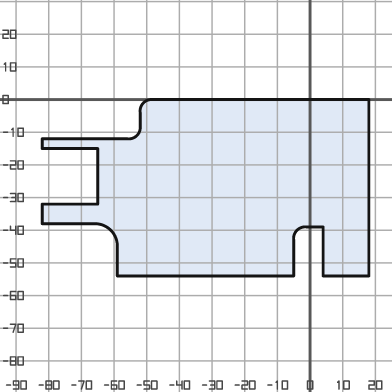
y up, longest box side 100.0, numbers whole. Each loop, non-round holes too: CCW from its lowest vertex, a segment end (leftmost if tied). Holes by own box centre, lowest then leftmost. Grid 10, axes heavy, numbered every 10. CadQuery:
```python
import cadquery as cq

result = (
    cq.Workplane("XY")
    .moveTo(-59.0, -54.0)
    .lineTo(-5.0, -54.0)
    .lineTo(-5.0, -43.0)
    .threePointArc((-4.0, -40.0), (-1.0, -39.0))
    .lineTo(4.0, -39.0)
    .lineTo(4.0, -54.0)
    .lineTo(18.0, -54.0)
    .lineTo(18.0, 0.0)
    .lineTo(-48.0, 0.0)
    .threePointArc((-51.0, -1.0), (-52.0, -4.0))
    .lineTo(-52.0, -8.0)
    .threePointArc((-53.0, -11.0), (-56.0, -12.0))
    .lineTo(-82.0, -12.0)
    .lineTo(-82.0, -15.0)
    .lineTo(-65.0, -15.0)
    .lineTo(-65.0, -32.0)
    .lineTo(-82.0, -32.0)
    .lineTo(-82.0, -38.0)
    .lineTo(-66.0, -38.0)
    .threePointArc((-61.0, -40.0), (-59.0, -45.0))
    .close()
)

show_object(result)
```